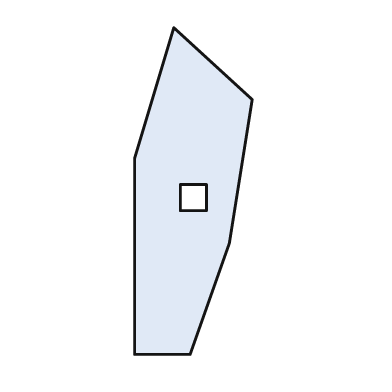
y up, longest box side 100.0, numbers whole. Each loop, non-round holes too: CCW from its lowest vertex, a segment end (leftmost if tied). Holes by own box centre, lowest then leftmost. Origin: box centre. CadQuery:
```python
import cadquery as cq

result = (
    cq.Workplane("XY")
    .moveTo(-18.0, -50.0)
    .lineTo(-1.0, -50.0)
    .lineTo(11.0, -16.0)
    .lineTo(18.0, 28.0)
    .lineTo(-6.0, 50.0)
    .lineTo(-18.0, 10.0)
    .close()
    .moveTo(-4.0, -6.0)
    .lineTo(4.0, -6.0)
    .lineTo(4.0, 2.0)
    .lineTo(-4.0, 2.0)
    .close()
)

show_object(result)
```